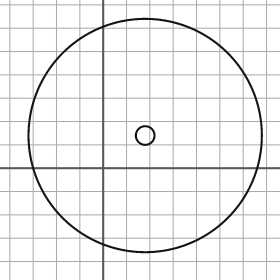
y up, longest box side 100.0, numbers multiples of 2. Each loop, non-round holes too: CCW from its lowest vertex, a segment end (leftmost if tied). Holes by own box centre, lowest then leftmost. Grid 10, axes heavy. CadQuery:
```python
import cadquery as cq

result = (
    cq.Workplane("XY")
    .moveTo(18.0, 14.0)
    .circle(50.0)
    .moveTo(18.0, 14.0)
    .circle(4.0)
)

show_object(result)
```